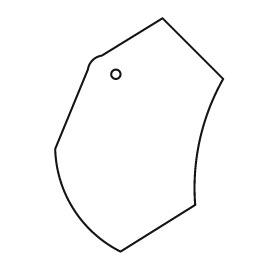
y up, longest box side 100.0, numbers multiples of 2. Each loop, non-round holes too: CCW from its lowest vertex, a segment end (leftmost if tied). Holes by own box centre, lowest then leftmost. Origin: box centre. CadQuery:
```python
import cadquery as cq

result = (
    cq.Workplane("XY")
    .moveTo(-8.0, -50.0)
    .lineTo(24.0, -30.0)
    .threePointArc((26.0, -2.0), (36.0, 24.0))
    .lineTo(10.0, 50.0)
    .lineTo(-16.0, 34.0)
    .threePointArc((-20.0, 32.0), (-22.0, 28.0))
    .lineTo(-36.0, -6.0)
    .threePointArc((-28.0, -32.0), (-8.0, -50.0))
    .close()
    .moveTo(-10.0, 26.0)
    .circle(2.0)
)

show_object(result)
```